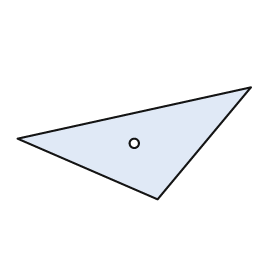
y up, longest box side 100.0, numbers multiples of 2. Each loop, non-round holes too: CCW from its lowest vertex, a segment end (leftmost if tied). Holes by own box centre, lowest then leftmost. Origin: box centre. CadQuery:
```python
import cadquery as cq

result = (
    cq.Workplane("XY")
    .moveTo(10.0, -24.0)
    .lineTo(50.0, 24.0)
    .lineTo(-50.0, 2.0)
    .close()
    .moveTo(0.0, 0.0)
    .circle(2.0)
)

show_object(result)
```